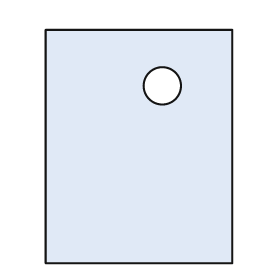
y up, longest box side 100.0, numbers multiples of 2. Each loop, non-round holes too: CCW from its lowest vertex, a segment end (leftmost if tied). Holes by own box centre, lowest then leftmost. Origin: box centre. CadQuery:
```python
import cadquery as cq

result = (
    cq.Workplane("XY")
    .moveTo(-40.0, -50.0)
    .lineTo(40.0, -50.0)
    .lineTo(40.0, 50.0)
    .lineTo(-40.0, 50.0)
    .close()
    .moveTo(10.0, 26.0)
    .circle(8.0)
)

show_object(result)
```